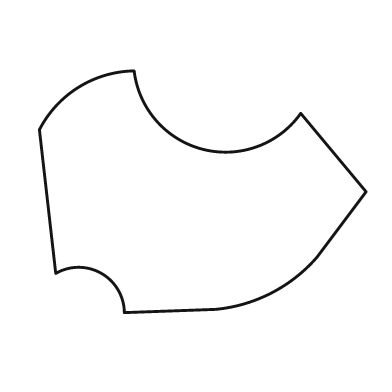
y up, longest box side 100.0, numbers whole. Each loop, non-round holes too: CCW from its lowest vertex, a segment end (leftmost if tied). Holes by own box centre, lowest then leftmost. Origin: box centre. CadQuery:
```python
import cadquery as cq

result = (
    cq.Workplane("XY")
    .moveTo(-24.0, -37.0)
    .lineTo(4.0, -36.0)
    .threePointArc((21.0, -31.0), (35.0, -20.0))
    .lineTo(50.0, 0.0)
    .lineTo(30.0, 24.0)
    .threePointArc((0.0, 13.0), (-21.0, 37.0))
    .threePointArc((-38.0, 32.0), (-50.0, 19.0))
    .lineTo(-45.0, -25.0)
    .threePointArc((-31.0, -25.0), (-24.0, -37.0))
    .close()
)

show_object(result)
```